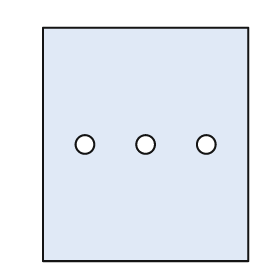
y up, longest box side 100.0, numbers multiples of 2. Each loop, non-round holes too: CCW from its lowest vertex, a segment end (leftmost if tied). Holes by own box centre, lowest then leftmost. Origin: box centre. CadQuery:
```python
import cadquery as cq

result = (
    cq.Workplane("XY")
    .moveTo(-44.0, -50.0)
    .lineTo(44.0, -50.0)
    .lineTo(44.0, 50.0)
    .lineTo(-44.0, 50.0)
    .close()
    .moveTo(-26.0, 0.0)
    .circle(4.0)
    .moveTo(0.0, 0.0)
    .circle(4.0)
    .moveTo(26.0, 0.0)
    .circle(4.0)
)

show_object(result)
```